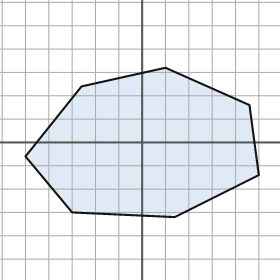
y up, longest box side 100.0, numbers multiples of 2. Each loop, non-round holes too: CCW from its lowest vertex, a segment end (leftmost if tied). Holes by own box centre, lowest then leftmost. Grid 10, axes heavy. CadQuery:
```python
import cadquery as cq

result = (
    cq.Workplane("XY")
    .moveTo(14.0, -32.0)
    .lineTo(50.0, -14.0)
    .lineTo(46.0, 16.0)
    .lineTo(10.0, 32.0)
    .lineTo(-26.0, 24.0)
    .lineTo(-50.0, -6.0)
    .lineTo(-30.0, -30.0)
    .close()
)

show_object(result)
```